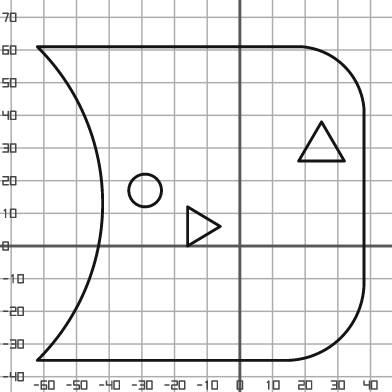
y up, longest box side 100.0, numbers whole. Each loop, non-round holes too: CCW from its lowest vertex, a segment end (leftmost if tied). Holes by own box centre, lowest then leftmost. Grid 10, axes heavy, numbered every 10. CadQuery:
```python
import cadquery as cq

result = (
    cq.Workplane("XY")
    .moveTo(-62.0, -35.0)
    .lineTo(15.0, -35.0)
    .threePointArc((31.0, -28.0), (38.0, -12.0))
    .lineTo(38.0, 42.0)
    .threePointArc((32.0, 55.0), (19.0, 61.0))
    .lineTo(-62.0, 61.0)
    .threePointArc((-42.0, 13.0), (-62.0, -35.0))
    .close()
    .moveTo(-16.0, 0.0)
    .lineTo(-6.0, 6.0)
    .lineTo(-16.0, 12.0)
    .close()
    .moveTo(-29.0, 17.0)
    .circle(5.0)
    .moveTo(18.0, 26.0)
    .lineTo(32.0, 26.0)
    .lineTo(25.0, 38.0)
    .close()
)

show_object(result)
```